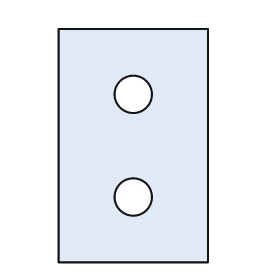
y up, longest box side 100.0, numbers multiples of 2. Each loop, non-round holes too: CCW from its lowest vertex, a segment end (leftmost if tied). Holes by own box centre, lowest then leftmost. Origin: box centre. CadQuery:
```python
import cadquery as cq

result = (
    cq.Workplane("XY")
    .moveTo(-32.0, -50.0)
    .lineTo(32.0, -50.0)
    .lineTo(32.0, 50.0)
    .lineTo(-32.0, 50.0)
    .close()
    .moveTo(0.0, -22.0)
    .circle(8.0)
    .moveTo(0.0, 22.0)
    .circle(8.0)
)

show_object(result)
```